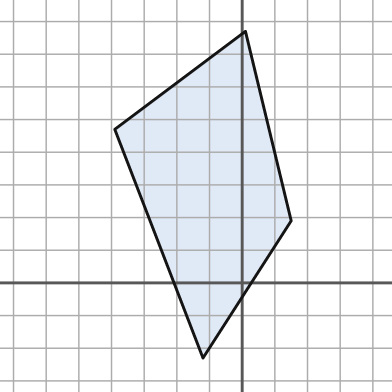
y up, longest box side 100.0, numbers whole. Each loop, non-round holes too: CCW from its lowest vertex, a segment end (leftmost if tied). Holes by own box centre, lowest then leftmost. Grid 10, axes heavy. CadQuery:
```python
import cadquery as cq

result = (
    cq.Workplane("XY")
    .moveTo(-12.0, -23.0)
    .lineTo(15.0, 19.0)
    .lineTo(1.0, 77.0)
    .lineTo(-39.0, 47.0)
    .close()
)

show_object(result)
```